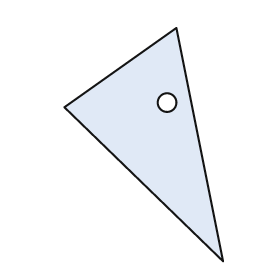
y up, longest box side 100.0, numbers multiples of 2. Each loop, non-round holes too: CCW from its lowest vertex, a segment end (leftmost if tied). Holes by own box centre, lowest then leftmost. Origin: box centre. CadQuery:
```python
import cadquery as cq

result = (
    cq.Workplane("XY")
    .moveTo(34.0, -50.0)
    .lineTo(14.0, 50.0)
    .lineTo(-34.0, 16.0)
    .close()
    .moveTo(10.0, 18.0)
    .circle(4.0)
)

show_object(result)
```